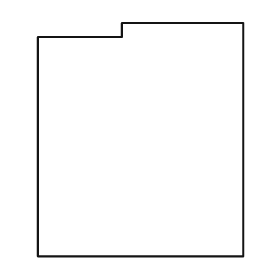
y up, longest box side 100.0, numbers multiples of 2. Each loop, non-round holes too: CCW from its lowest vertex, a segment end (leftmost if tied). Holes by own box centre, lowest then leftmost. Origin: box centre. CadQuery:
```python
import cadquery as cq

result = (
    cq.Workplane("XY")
    .moveTo(-44.0, -50.0)
    .lineTo(44.0, -50.0)
    .lineTo(44.0, 50.0)
    .lineTo(-8.0, 50.0)
    .lineTo(-8.0, 44.0)
    .lineTo(-44.0, 44.0)
    .close()
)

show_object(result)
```